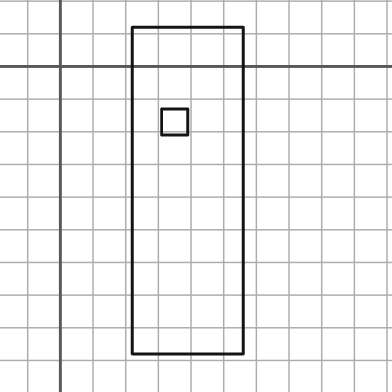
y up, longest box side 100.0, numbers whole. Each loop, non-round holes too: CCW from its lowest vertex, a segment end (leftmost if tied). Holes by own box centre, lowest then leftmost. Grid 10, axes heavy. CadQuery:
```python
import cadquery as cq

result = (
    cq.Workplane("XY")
    .moveTo(22.0, -88.0)
    .lineTo(56.0, -88.0)
    .lineTo(56.0, 12.0)
    .lineTo(22.0, 12.0)
    .close()
    .moveTo(31.0, -21.0)
    .lineTo(39.0, -21.0)
    .lineTo(39.0, -13.0)
    .lineTo(31.0, -13.0)
    .close()
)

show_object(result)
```